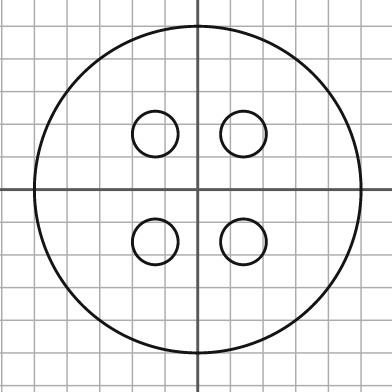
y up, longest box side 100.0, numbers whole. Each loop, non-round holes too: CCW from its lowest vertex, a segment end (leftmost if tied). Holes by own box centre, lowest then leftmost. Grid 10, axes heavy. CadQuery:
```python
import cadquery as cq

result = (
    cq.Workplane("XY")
    .moveTo(0.0, 0.0)
    .circle(50.0)
    .moveTo(-13.0, -16.0)
    .circle(7.0)
    .moveTo(14.0, -16.0)
    .circle(7.0)
    .moveTo(-13.0, 17.0)
    .circle(7.0)
    .moveTo(14.0, 17.0)
    .circle(7.0)
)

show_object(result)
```